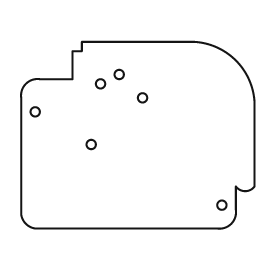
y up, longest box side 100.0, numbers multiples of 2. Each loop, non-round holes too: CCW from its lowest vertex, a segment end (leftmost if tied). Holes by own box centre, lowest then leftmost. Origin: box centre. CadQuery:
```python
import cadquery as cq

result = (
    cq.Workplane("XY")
    .moveTo(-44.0, -40.0)
    .lineTo(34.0, -40.0)
    .threePointArc((40.0, -38.0), (42.0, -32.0))
    .lineTo(42.0, -22.0)
    .threePointArc((46.0, -24.0), (50.0, -22.0))
    .lineTo(50.0, 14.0)
    .threePointArc((42.0, 32.0), (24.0, 40.0))
    .lineTo(-24.0, 40.0)
    .lineTo(-24.0, 36.0)
    .lineTo(-28.0, 36.0)
    .lineTo(-28.0, 24.0)
    .lineTo(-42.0, 24.0)
    .threePointArc((-48.0, 22.0), (-50.0, 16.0))
    .lineTo(-50.0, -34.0)
    .threePointArc((-48.0, -38.0), (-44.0, -40.0))
    .close()
    .moveTo(36.0, -30.0)
    .circle(2.0)
    .moveTo(-20.0, -4.0)
    .circle(2.0)
    .moveTo(-44.0, 10.0)
    .circle(2.0)
    .moveTo(2.0, 16.0)
    .circle(2.0)
    .moveTo(-16.0, 22.0)
    .circle(2.0)
    .moveTo(-8.0, 26.0)
    .circle(2.0)
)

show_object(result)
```